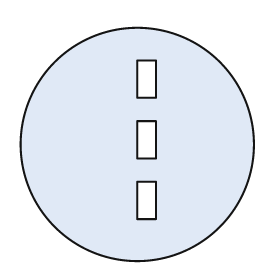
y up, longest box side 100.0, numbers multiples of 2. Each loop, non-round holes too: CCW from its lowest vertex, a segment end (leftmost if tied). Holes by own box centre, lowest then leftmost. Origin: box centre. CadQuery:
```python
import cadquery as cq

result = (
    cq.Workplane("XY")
    .moveTo(0.0, 0.0)
    .circle(50.0)
    .moveTo(0.0, -32.0)
    .lineTo(8.0, -32.0)
    .lineTo(8.0, -16.0)
    .lineTo(0.0, -16.0)
    .close()
    .moveTo(0.0, -6.0)
    .lineTo(8.0, -6.0)
    .lineTo(8.0, 10.0)
    .lineTo(0.0, 10.0)
    .close()
    .moveTo(0.0, 20.0)
    .lineTo(8.0, 20.0)
    .lineTo(8.0, 36.0)
    .lineTo(0.0, 36.0)
    .close()
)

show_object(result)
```